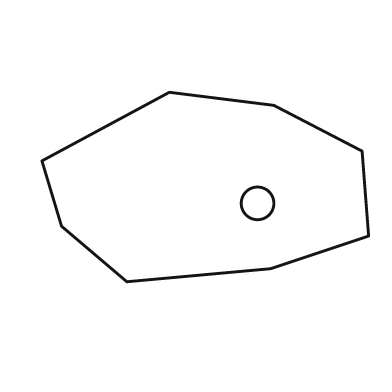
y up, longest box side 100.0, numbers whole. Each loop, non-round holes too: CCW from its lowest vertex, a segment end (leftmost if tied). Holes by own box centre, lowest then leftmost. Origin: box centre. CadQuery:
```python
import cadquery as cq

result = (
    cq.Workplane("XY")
    .moveTo(-24.0, -29.0)
    .lineTo(20.0, -25.0)
    .lineTo(50.0, -15.0)
    .lineTo(48.0, 11.0)
    .lineTo(21.0, 25.0)
    .lineTo(-11.0, 29.0)
    .lineTo(-50.0, 8.0)
    .lineTo(-44.0, -12.0)
    .close()
    .moveTo(16.0, -5.0)
    .circle(5.0)
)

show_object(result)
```